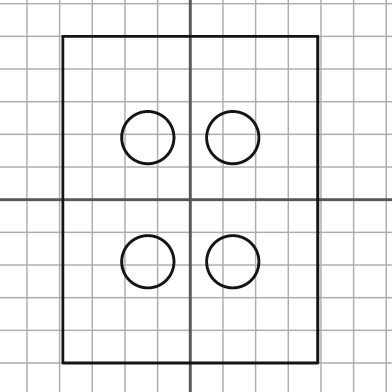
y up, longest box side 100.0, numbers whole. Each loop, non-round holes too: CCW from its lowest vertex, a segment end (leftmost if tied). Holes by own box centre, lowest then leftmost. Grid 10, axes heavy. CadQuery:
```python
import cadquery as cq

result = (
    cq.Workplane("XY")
    .moveTo(-39.0, -50.0)
    .lineTo(39.0, -50.0)
    .lineTo(39.0, 50.0)
    .lineTo(-39.0, 50.0)
    .close()
    .moveTo(-13.0, -19.0)
    .circle(8.0)
    .moveTo(13.0, -19.0)
    .circle(8.0)
    .moveTo(-13.0, 19.0)
    .circle(8.0)
    .moveTo(13.0, 19.0)
    .circle(8.0)
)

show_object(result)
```